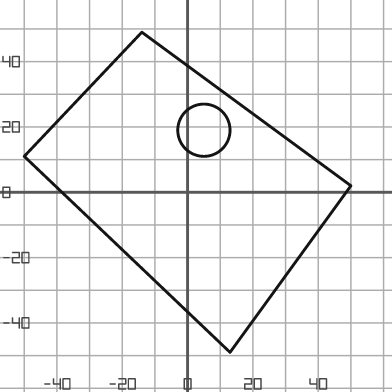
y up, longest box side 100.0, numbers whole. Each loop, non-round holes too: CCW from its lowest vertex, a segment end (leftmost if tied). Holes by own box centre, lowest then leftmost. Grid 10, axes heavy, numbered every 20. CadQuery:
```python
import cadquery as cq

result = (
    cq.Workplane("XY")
    .moveTo(13.0, -49.0)
    .lineTo(50.0, 2.0)
    .lineTo(-14.0, 49.0)
    .lineTo(-50.0, 11.0)
    .close()
    .moveTo(5.0, 19.0)
    .circle(8.0)
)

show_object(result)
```